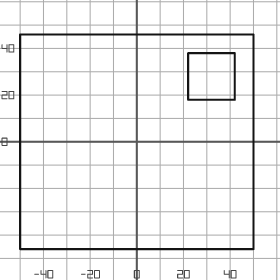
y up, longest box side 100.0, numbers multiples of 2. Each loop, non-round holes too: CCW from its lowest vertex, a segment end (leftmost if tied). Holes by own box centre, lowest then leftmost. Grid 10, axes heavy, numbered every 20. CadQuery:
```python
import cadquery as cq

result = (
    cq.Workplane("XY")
    .moveTo(-50.0, -46.0)
    .lineTo(50.0, -46.0)
    .lineTo(50.0, 46.0)
    .lineTo(-50.0, 46.0)
    .close()
    .moveTo(22.0, 18.0)
    .lineTo(42.0, 18.0)
    .lineTo(42.0, 38.0)
    .lineTo(22.0, 38.0)
    .close()
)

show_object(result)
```